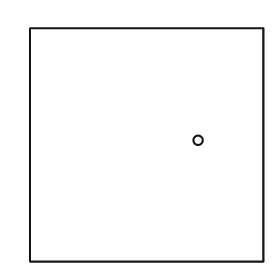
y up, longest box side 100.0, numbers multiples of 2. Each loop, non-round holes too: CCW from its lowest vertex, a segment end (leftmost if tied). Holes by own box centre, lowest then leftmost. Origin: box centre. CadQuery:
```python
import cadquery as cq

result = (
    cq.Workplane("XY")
    .moveTo(-50.0, -50.0)
    .lineTo(50.0, -50.0)
    .lineTo(50.0, 50.0)
    .lineTo(-50.0, 50.0)
    .close()
    .moveTo(22.0, 2.0)
    .circle(2.0)
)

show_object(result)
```